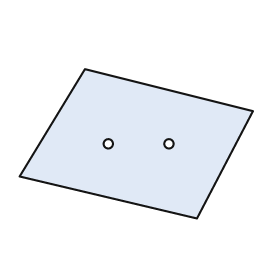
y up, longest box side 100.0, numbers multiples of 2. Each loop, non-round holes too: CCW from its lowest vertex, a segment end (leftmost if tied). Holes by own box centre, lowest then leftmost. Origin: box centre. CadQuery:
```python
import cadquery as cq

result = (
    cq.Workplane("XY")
    .moveTo(26.0, -32.0)
    .lineTo(50.0, 14.0)
    .lineTo(-22.0, 32.0)
    .lineTo(-50.0, -14.0)
    .close()
    .moveTo(-12.0, 0.0)
    .circle(2.0)
    .moveTo(14.0, 0.0)
    .circle(2.0)
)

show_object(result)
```